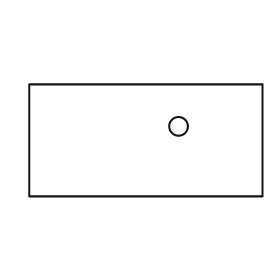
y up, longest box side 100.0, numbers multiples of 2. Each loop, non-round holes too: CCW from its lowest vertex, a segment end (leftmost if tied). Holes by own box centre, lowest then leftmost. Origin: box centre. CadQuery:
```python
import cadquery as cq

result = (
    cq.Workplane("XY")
    .moveTo(-50.0, -24.0)
    .lineTo(50.0, -24.0)
    .lineTo(50.0, 24.0)
    .lineTo(-50.0, 24.0)
    .close()
    .moveTo(14.0, 6.0)
    .circle(4.0)
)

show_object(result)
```